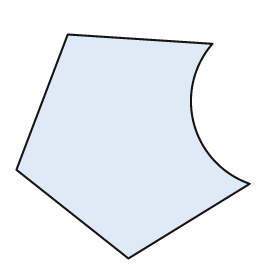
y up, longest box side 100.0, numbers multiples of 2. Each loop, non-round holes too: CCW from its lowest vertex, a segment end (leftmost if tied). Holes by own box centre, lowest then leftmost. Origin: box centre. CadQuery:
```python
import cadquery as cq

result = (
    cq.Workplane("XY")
    .moveTo(-2.0, -48.0)
    .lineTo(50.0, -16.0)
    .threePointArc((26.0, 10.0), (34.0, 44.0))
    .lineTo(-28.0, 48.0)
    .lineTo(-50.0, -10.0)
    .close()
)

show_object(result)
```